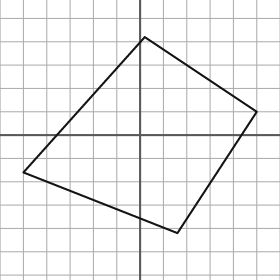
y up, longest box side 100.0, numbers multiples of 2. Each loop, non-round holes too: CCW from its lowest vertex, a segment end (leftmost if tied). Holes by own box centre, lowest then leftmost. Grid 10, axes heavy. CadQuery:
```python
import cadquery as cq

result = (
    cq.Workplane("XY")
    .moveTo(16.0, -42.0)
    .lineTo(50.0, 10.0)
    .lineTo(2.0, 42.0)
    .lineTo(-50.0, -16.0)
    .close()
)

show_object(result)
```